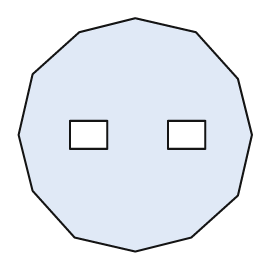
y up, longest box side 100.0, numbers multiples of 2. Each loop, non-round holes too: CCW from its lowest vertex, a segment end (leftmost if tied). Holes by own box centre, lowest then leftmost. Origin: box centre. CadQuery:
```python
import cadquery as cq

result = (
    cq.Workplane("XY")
    .moveTo(0.0, -50.0)
    .lineTo(24.0, -44.0)
    .lineTo(44.0, -26.0)
    .lineTo(50.0, 0.0)
    .lineTo(44.0, 24.0)
    .lineTo(26.0, 44.0)
    .lineTo(0.0, 50.0)
    .lineTo(-24.0, 44.0)
    .lineTo(-44.0, 26.0)
    .lineTo(-50.0, 0.0)
    .lineTo(-44.0, -24.0)
    .lineTo(-26.0, -44.0)
    .close()
    .moveTo(-28.0, -6.0)
    .lineTo(-12.0, -6.0)
    .lineTo(-12.0, 6.0)
    .lineTo(-28.0, 6.0)
    .close()
    .moveTo(14.0, -6.0)
    .lineTo(30.0, -6.0)
    .lineTo(30.0, 6.0)
    .lineTo(14.0, 6.0)
    .close()
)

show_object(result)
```